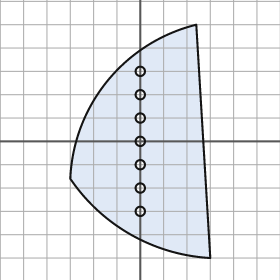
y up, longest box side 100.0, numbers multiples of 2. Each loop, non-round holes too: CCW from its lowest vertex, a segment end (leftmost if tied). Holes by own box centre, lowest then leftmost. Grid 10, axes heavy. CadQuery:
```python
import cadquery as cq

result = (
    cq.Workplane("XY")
    .moveTo(30.0, -50.0)
    .lineTo(24.0, 50.0)
    .threePointArc((-14.0, 26.0), (-30.0, -16.0))
    .threePointArc((-4.0, -40.0), (30.0, -50.0))
    .close()
    .moveTo(0.0, -30.0)
    .circle(2.0)
    .moveTo(0.0, -20.0)
    .circle(2.0)
    .moveTo(0.0, -10.0)
    .circle(2.0)
    .moveTo(0.0, 0.0)
    .circle(2.0)
    .moveTo(0.0, 10.0)
    .circle(2.0)
    .moveTo(0.0, 20.0)
    .circle(2.0)
    .moveTo(0.0, 30.0)
    .circle(2.0)
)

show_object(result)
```